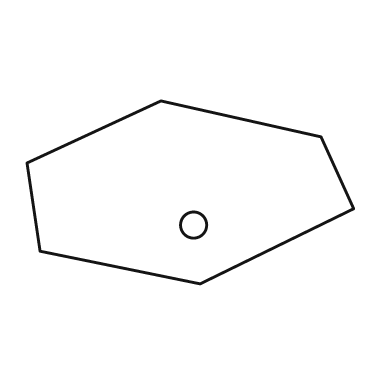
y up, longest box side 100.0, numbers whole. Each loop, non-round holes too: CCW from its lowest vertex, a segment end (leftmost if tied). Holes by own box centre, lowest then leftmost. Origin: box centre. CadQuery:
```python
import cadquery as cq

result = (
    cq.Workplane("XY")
    .moveTo(3.0, -28.0)
    .lineTo(50.0, -5.0)
    .lineTo(40.0, 17.0)
    .lineTo(-9.0, 28.0)
    .lineTo(-50.0, 9.0)
    .lineTo(-46.0, -18.0)
    .close()
    .moveTo(1.0, -10.0)
    .circle(4.0)
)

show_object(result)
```